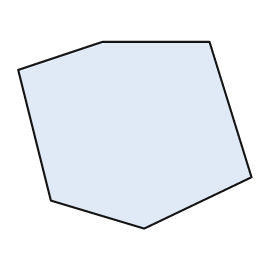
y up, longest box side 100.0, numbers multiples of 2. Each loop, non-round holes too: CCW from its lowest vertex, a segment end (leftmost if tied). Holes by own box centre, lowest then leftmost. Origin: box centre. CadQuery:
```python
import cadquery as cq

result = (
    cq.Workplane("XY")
    .moveTo(4.0, -40.0)
    .lineTo(50.0, -18.0)
    .lineTo(32.0, 40.0)
    .lineTo(-14.0, 40.0)
    .lineTo(-50.0, 28.0)
    .lineTo(-36.0, -28.0)
    .close()
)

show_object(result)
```